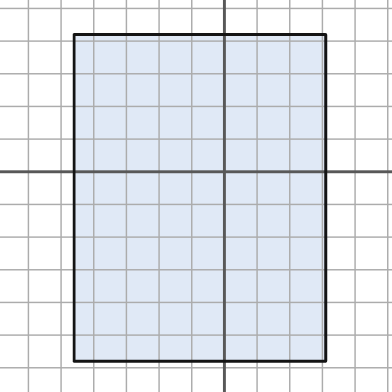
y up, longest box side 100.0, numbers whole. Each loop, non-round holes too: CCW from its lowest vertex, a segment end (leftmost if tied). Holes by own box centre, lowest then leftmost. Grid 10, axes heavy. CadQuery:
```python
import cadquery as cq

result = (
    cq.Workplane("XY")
    .moveTo(-46.0, -58.0)
    .lineTo(31.0, -58.0)
    .lineTo(31.0, 42.0)
    .lineTo(-46.0, 42.0)
    .close()
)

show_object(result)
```